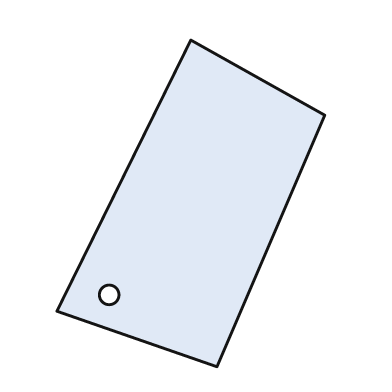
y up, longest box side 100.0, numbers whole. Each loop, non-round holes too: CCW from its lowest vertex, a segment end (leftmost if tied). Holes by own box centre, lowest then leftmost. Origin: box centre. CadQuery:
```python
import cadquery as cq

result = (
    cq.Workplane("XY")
    .moveTo(8.0, -50.0)
    .lineTo(41.0, 27.0)
    .lineTo(0.0, 50.0)
    .lineTo(-41.0, -33.0)
    .close()
    .moveTo(-25.0, -28.0)
    .circle(3.0)
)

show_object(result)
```